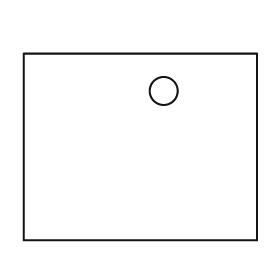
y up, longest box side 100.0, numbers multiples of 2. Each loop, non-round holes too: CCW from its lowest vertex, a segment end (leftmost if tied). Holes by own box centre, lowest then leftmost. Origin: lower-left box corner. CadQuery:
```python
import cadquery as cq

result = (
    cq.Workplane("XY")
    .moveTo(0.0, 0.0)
    .lineTo(100.0, 0.0)
    .lineTo(100.0, 80.0)
    .lineTo(0.0, 80.0)
    .close()
    .moveTo(60.0, 64.0)
    .circle(6.0)
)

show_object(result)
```